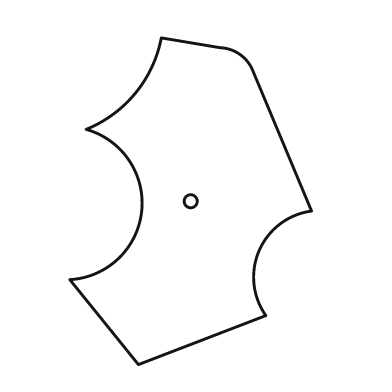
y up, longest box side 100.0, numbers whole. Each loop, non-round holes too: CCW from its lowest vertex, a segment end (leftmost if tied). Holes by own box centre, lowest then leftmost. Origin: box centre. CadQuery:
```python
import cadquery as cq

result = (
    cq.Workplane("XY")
    .moveTo(-16.0, -50.0)
    .lineTo(23.0, -35.0)
    .threePointArc((21.0, -15.0), (37.0, -3.0))
    .lineTo(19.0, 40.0)
    .threePointArc((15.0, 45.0), (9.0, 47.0))
    .lineTo(-9.0, 50.0)
    .threePointArc((-17.0, 33.0), (-32.0, 22.0))
    .threePointArc((-15.0, -3.0), (-37.0, -24.0))
    .close()
    .moveTo(0.0, 0.0)
    .circle(2.0)
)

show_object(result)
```